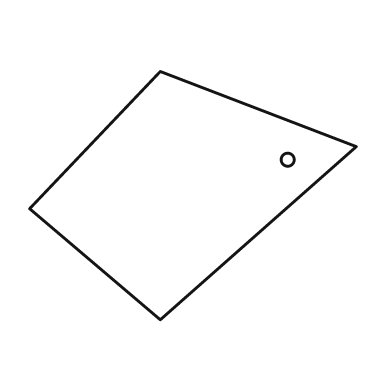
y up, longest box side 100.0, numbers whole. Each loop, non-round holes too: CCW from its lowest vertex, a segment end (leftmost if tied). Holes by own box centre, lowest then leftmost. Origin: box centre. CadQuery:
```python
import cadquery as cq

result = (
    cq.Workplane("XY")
    .moveTo(-10.0, -38.0)
    .lineTo(50.0, 15.0)
    .lineTo(-10.0, 38.0)
    .lineTo(-50.0, -4.0)
    .close()
    .moveTo(29.0, 11.0)
    .circle(2.0)
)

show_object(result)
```